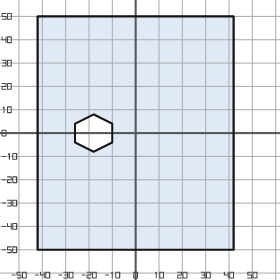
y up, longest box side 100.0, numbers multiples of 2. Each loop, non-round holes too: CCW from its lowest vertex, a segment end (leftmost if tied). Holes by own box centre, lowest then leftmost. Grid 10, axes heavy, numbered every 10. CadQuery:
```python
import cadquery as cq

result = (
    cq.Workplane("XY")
    .moveTo(-42.0, -50.0)
    .lineTo(42.0, -50.0)
    .lineTo(42.0, 50.0)
    .lineTo(-42.0, 50.0)
    .close()
    .moveTo(-18.0, -8.0)
    .lineTo(-10.0, -4.0)
    .lineTo(-10.0, 4.0)
    .lineTo(-18.0, 8.0)
    .lineTo(-26.0, 4.0)
    .lineTo(-26.0, -4.0)
    .close()
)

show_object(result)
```